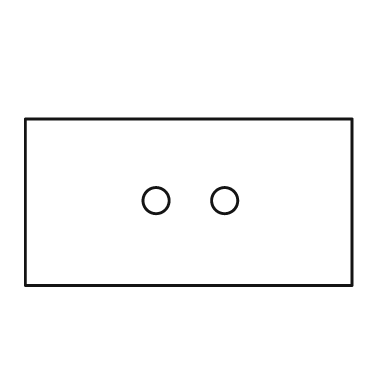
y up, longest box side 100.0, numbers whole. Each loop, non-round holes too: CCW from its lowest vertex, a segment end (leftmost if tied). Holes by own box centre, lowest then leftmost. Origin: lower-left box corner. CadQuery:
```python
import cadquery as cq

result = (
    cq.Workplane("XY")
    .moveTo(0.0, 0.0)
    .lineTo(100.0, 0.0)
    .lineTo(100.0, 51.0)
    .lineTo(0.0, 51.0)
    .close()
    .moveTo(40.0, 26.0)
    .circle(4.0)
    .moveTo(61.0, 26.0)
    .circle(4.0)
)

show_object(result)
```